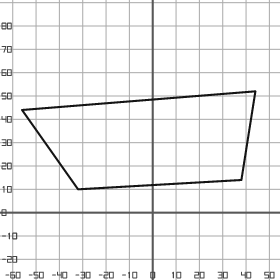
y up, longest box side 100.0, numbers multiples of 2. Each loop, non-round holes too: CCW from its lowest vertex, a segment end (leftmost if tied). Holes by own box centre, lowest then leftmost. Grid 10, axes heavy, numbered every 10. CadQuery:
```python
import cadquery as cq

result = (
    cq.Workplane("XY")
    .moveTo(-32.0, 10.0)
    .lineTo(38.0, 14.0)
    .lineTo(44.0, 52.0)
    .lineTo(-56.0, 44.0)
    .close()
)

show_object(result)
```